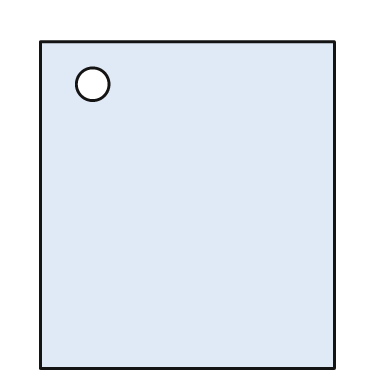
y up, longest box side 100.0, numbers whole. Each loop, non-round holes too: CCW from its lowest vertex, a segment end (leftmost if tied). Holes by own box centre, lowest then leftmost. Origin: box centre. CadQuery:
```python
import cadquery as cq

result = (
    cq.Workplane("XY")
    .moveTo(-45.0, -50.0)
    .lineTo(45.0, -50.0)
    .lineTo(45.0, 50.0)
    .lineTo(-45.0, 50.0)
    .close()
    .moveTo(-29.0, 37.0)
    .circle(5.0)
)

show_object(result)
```